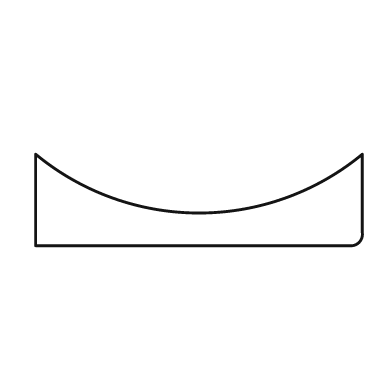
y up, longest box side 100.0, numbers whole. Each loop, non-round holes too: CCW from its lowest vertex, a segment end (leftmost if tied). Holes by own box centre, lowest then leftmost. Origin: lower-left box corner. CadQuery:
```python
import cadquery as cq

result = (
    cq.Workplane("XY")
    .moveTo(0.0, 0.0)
    .lineTo(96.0, 0.0)
    .threePointArc((99.0, 1.0), (100.0, 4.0))
    .lineTo(100.0, 28.0)
    .threePointArc((50.0, 10.0), (0.0, 28.0))
    .close()
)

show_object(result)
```